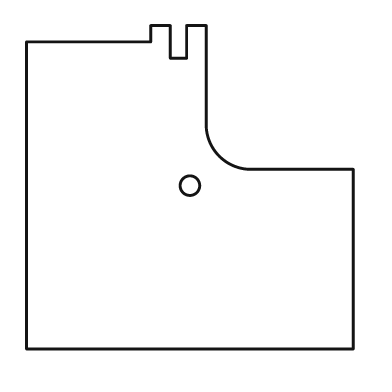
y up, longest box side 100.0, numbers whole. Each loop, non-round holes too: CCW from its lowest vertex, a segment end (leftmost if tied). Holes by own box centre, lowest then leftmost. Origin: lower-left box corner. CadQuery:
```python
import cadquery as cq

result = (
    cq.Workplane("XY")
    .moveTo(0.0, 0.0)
    .lineTo(100.0, 0.0)
    .lineTo(100.0, 55.0)
    .lineTo(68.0, 55.0)
    .threePointArc((59.0, 59.0), (55.0, 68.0))
    .lineTo(55.0, 99.0)
    .lineTo(49.0, 99.0)
    .lineTo(49.0, 89.0)
    .lineTo(44.0, 89.0)
    .lineTo(44.0, 99.0)
    .lineTo(38.0, 99.0)
    .lineTo(38.0, 94.0)
    .lineTo(0.0, 94.0)
    .close()
    .moveTo(50.0, 50.0)
    .circle(3.0)
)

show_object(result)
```